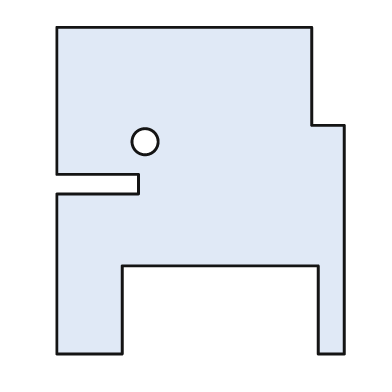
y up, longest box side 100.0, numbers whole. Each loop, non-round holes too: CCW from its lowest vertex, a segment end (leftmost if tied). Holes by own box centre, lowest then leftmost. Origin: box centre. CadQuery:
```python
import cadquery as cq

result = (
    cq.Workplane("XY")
    .moveTo(-44.0, -50.0)
    .lineTo(-24.0, -50.0)
    .lineTo(-24.0, -23.0)
    .lineTo(36.0, -23.0)
    .lineTo(36.0, -50.0)
    .lineTo(44.0, -50.0)
    .lineTo(44.0, 20.0)
    .lineTo(34.0, 20.0)
    .lineTo(34.0, 50.0)
    .lineTo(-44.0, 50.0)
    .lineTo(-44.0, 5.0)
    .lineTo(-19.0, 5.0)
    .lineTo(-19.0, -1.0)
    .lineTo(-44.0, -1.0)
    .close()
    .moveTo(-17.0, 15.0)
    .circle(4.0)
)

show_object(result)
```